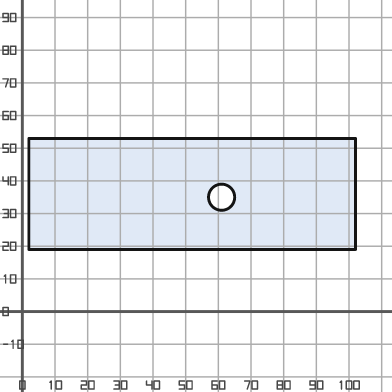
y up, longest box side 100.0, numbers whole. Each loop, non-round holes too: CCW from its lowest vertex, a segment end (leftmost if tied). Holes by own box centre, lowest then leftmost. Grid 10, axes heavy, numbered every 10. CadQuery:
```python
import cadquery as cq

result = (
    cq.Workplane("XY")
    .moveTo(2.0, 19.0)
    .lineTo(102.0, 19.0)
    .lineTo(102.0, 53.0)
    .lineTo(2.0, 53.0)
    .close()
    .moveTo(61.0, 35.0)
    .circle(4.0)
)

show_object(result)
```